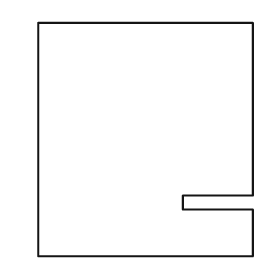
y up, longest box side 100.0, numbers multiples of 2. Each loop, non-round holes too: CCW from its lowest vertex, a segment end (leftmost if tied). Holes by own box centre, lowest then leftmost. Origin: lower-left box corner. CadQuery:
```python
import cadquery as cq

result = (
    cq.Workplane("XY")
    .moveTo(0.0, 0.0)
    .lineTo(92.0, 0.0)
    .lineTo(92.0, 20.0)
    .lineTo(62.0, 20.0)
    .lineTo(62.0, 26.0)
    .lineTo(92.0, 26.0)
    .lineTo(92.0, 100.0)
    .lineTo(0.0, 100.0)
    .close()
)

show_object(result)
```